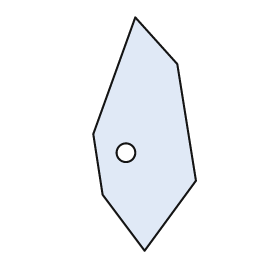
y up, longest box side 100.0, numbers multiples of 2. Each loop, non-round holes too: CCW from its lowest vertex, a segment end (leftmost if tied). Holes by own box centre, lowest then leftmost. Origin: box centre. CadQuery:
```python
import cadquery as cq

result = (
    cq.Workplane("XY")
    .moveTo(0.0, -50.0)
    .lineTo(22.0, -20.0)
    .lineTo(14.0, 30.0)
    .lineTo(-4.0, 50.0)
    .lineTo(-22.0, 0.0)
    .lineTo(-18.0, -26.0)
    .close()
    .moveTo(-8.0, -8.0)
    .circle(4.0)
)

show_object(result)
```